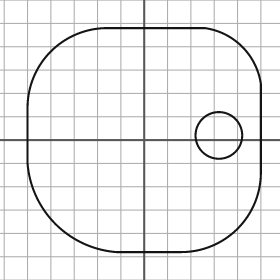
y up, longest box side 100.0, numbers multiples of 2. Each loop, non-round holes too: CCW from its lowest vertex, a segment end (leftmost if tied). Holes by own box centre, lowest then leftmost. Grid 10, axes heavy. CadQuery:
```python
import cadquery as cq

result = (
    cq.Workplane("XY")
    .moveTo(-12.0, -48.0)
    .lineTo(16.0, -48.0)
    .threePointArc((40.0, -38.0), (50.0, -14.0))
    .lineTo(50.0, 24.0)
    .threePointArc((42.0, 40.0), (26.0, 48.0))
    .lineTo(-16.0, 48.0)
    .threePointArc((-40.0, 38.0), (-50.0, 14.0))
    .lineTo(-50.0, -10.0)
    .threePointArc((-38.0, -36.0), (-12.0, -48.0))
    .close()
    .moveTo(32.0, 2.0)
    .circle(10.0)
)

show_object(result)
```